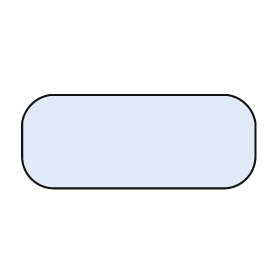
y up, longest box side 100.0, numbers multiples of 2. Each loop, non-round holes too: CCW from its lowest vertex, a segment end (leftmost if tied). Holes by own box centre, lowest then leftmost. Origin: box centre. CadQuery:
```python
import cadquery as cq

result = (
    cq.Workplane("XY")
    .moveTo(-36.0, -20.0)
    .lineTo(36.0, -20.0)
    .threePointArc((46.0, -16.0), (50.0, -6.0))
    .lineTo(50.0, 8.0)
    .threePointArc((46.0, 16.0), (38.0, 20.0))
    .lineTo(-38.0, 20.0)
    .threePointArc((-46.0, 16.0), (-50.0, 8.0))
    .lineTo(-50.0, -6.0)
    .threePointArc((-46.0, -16.0), (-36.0, -20.0))
    .close()
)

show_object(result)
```